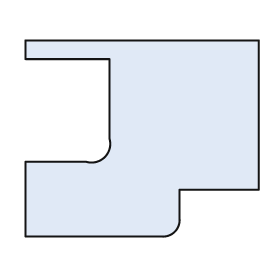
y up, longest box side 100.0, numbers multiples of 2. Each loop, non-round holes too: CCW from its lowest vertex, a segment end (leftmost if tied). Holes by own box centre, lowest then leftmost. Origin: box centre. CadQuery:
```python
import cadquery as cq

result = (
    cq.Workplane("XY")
    .moveTo(-50.0, -42.0)
    .lineTo(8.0, -42.0)
    .threePointArc((14.0, -40.0), (16.0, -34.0))
    .lineTo(16.0, -22.0)
    .lineTo(50.0, -22.0)
    .lineTo(50.0, 42.0)
    .lineTo(-50.0, 42.0)
    .lineTo(-50.0, 34.0)
    .lineTo(-14.0, 34.0)
    .lineTo(-14.0, 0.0)
    .threePointArc((-16.0, -8.0), (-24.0, -10.0))
    .lineTo(-50.0, -10.0)
    .close()
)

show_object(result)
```